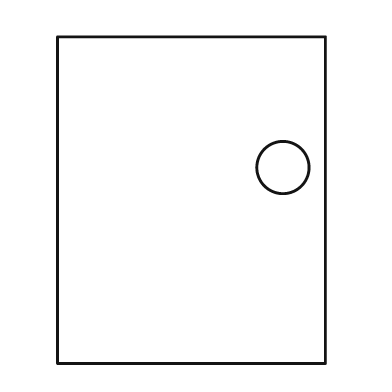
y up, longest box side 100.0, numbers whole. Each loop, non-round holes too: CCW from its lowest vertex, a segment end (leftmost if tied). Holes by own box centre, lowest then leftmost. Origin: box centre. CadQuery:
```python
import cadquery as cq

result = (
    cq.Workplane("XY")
    .moveTo(-41.0, -50.0)
    .lineTo(41.0, -50.0)
    .lineTo(41.0, 50.0)
    .lineTo(-41.0, 50.0)
    .close()
    .moveTo(28.0, 10.0)
    .circle(8.0)
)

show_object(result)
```